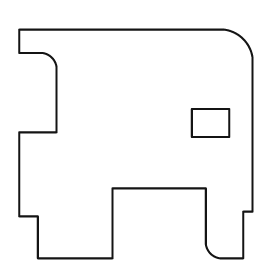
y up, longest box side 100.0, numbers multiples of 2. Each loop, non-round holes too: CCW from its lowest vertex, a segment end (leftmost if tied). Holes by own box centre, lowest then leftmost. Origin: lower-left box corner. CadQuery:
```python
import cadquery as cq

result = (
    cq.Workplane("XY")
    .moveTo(8.0, 0.0)
    .lineTo(40.0, 0.0)
    .lineTo(40.0, 30.0)
    .lineTo(80.0, 30.0)
    .lineTo(80.0, 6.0)
    .threePointArc((82.0, 2.0), (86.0, 0.0))
    .lineTo(96.0, 0.0)
    .lineTo(96.0, 20.0)
    .lineTo(100.0, 20.0)
    .lineTo(100.0, 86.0)
    .threePointArc((96.0, 94.0), (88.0, 98.0))
    .lineTo(0.0, 98.0)
    .lineTo(0.0, 88.0)
    .lineTo(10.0, 88.0)
    .threePointArc((14.0, 86.0), (16.0, 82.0))
    .lineTo(16.0, 54.0)
    .lineTo(0.0, 54.0)
    .lineTo(0.0, 18.0)
    .lineTo(8.0, 18.0)
    .close()
    .moveTo(74.0, 52.0)
    .lineTo(90.0, 52.0)
    .lineTo(90.0, 64.0)
    .lineTo(74.0, 64.0)
    .close()
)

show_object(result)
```